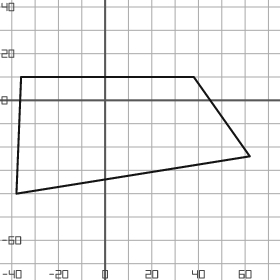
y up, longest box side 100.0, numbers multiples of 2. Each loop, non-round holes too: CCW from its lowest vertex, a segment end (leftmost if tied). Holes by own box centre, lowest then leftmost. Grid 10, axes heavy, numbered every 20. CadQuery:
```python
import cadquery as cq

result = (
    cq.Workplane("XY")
    .moveTo(-38.0, -40.0)
    .lineTo(62.0, -24.0)
    .lineTo(38.0, 10.0)
    .lineTo(-36.0, 10.0)
    .close()
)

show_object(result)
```